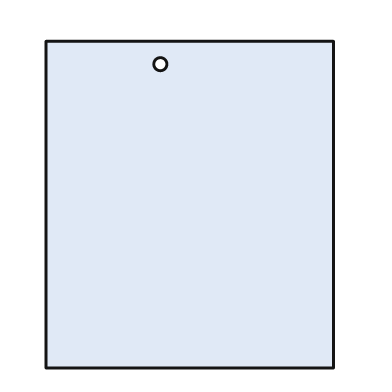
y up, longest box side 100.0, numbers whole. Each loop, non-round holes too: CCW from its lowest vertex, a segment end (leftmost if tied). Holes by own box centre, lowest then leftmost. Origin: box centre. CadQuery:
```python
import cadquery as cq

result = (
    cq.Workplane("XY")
    .moveTo(-44.0, -50.0)
    .lineTo(44.0, -50.0)
    .lineTo(44.0, 50.0)
    .lineTo(-44.0, 50.0)
    .close()
    .moveTo(-9.0, 43.0)
    .circle(2.0)
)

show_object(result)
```